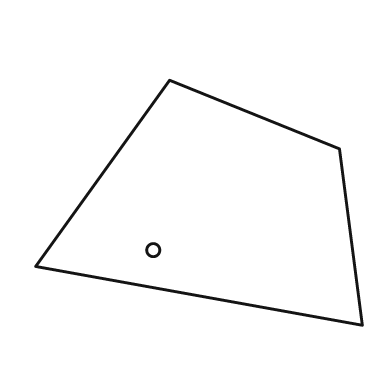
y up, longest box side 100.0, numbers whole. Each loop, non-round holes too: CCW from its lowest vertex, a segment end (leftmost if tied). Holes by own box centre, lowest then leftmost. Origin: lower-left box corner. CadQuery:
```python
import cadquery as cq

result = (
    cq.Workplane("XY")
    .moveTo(100.0, 0.0)
    .lineTo(93.0, 54.0)
    .lineTo(41.0, 75.0)
    .lineTo(0.0, 18.0)
    .close()
    .moveTo(36.0, 23.0)
    .circle(2.0)
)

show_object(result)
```